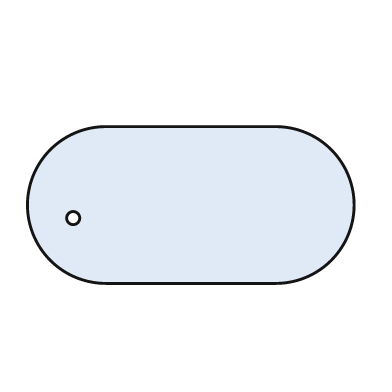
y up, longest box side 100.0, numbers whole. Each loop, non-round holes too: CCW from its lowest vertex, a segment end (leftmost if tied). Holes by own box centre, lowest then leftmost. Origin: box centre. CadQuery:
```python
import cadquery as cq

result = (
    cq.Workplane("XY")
    .moveTo(-26.0, -24.0)
    .lineTo(26.0, -24.0)
    .threePointArc((50.0, 0.0), (26.0, 24.0))
    .lineTo(-26.0, 24.0)
    .threePointArc((-50.0, 0.0), (-26.0, -24.0))
    .close()
    .moveTo(-36.0, -4.0)
    .circle(2.0)
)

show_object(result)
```